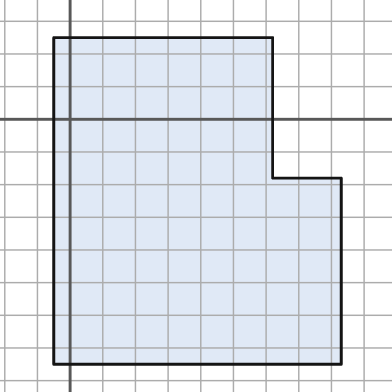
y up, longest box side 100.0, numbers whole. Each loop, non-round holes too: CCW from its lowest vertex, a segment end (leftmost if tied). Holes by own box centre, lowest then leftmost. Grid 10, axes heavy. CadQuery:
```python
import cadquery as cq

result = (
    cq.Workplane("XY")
    .moveTo(-5.0, -75.0)
    .lineTo(83.0, -75.0)
    .lineTo(83.0, -18.0)
    .lineTo(62.0, -18.0)
    .lineTo(62.0, 25.0)
    .lineTo(-5.0, 25.0)
    .close()
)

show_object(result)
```